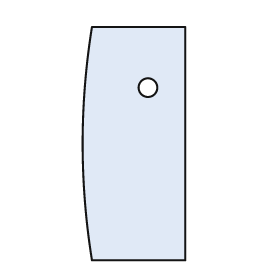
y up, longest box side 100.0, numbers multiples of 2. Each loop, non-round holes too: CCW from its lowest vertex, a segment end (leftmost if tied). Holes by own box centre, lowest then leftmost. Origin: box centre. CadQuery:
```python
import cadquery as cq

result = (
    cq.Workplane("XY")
    .moveTo(-18.0, -50.0)
    .lineTo(22.0, -50.0)
    .lineTo(22.0, 50.0)
    .lineTo(-18.0, 50.0)
    .threePointArc((-22.0, 0.0), (-18.0, -50.0))
    .close()
    .moveTo(6.0, 24.0)
    .circle(4.0)
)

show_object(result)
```